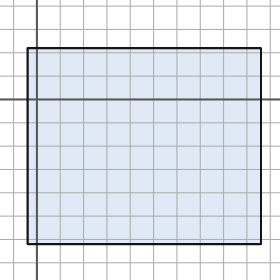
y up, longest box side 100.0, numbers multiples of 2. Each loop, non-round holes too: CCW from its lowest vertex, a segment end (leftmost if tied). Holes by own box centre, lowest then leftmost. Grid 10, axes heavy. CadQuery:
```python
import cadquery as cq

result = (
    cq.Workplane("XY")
    .moveTo(-4.0, -62.0)
    .lineTo(96.0, -62.0)
    .lineTo(96.0, 22.0)
    .lineTo(-4.0, 22.0)
    .close()
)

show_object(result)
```